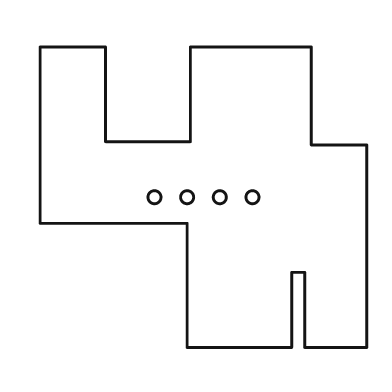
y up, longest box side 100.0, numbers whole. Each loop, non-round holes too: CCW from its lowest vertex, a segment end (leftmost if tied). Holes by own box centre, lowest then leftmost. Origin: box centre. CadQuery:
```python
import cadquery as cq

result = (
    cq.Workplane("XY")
    .moveTo(-5.0, -46.0)
    .lineTo(27.0, -46.0)
    .lineTo(27.0, -23.0)
    .lineTo(31.0, -23.0)
    .lineTo(31.0, -46.0)
    .lineTo(50.0, -46.0)
    .lineTo(50.0, 16.0)
    .lineTo(33.0, 16.0)
    .lineTo(33.0, 46.0)
    .lineTo(-4.0, 46.0)
    .lineTo(-4.0, 17.0)
    .lineTo(-30.0, 17.0)
    .lineTo(-30.0, 46.0)
    .lineTo(-50.0, 46.0)
    .lineTo(-50.0, -8.0)
    .lineTo(-5.0, -8.0)
    .close()
    .moveTo(-15.0, 0.0)
    .circle(2.0)
    .moveTo(-5.0, 0.0)
    .circle(2.0)
    .moveTo(5.0, 0.0)
    .circle(2.0)
    .moveTo(15.0, 0.0)
    .circle(2.0)
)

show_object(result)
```